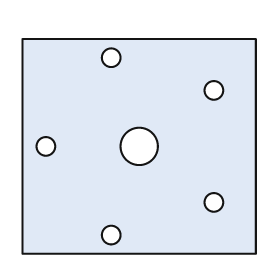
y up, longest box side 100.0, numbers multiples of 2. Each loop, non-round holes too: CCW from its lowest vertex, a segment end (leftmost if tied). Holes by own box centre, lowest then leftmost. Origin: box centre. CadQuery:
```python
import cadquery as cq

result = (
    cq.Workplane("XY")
    .moveTo(-50.0, -46.0)
    .lineTo(50.0, -46.0)
    .lineTo(50.0, 46.0)
    .lineTo(-50.0, 46.0)
    .close()
    .moveTo(-12.0, -38.0)
    .circle(4.0)
    .moveTo(32.0, -24.0)
    .circle(4.0)
    .moveTo(-40.0, 0.0)
    .circle(4.0)
    .moveTo(0.0, 0.0)
    .circle(8.0)
    .moveTo(32.0, 24.0)
    .circle(4.0)
    .moveTo(-12.0, 38.0)
    .circle(4.0)
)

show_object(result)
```